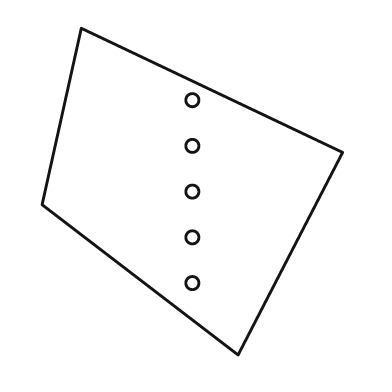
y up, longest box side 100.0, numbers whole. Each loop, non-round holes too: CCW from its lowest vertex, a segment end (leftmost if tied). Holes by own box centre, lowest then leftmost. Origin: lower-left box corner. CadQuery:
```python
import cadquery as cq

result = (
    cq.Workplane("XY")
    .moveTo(60.0, 0.0)
    .lineTo(92.0, 62.0)
    .lineTo(12.0, 100.0)
    .lineTo(0.0, 46.0)
    .close()
    .moveTo(46.0, 22.0)
    .circle(2.0)
    .moveTo(46.0, 36.0)
    .circle(2.0)
    .moveTo(46.0, 50.0)
    .circle(2.0)
    .moveTo(46.0, 64.0)
    .circle(2.0)
    .moveTo(46.0, 78.0)
    .circle(2.0)
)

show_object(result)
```